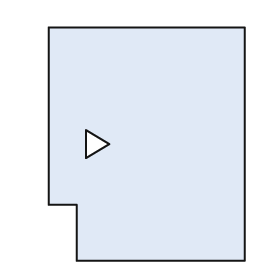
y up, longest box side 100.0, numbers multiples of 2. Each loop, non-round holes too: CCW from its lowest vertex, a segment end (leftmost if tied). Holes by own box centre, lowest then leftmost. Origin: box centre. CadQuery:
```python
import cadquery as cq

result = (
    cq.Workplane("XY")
    .moveTo(-30.0, -50.0)
    .lineTo(42.0, -50.0)
    .lineTo(42.0, 50.0)
    .lineTo(-42.0, 50.0)
    .lineTo(-42.0, -26.0)
    .lineTo(-30.0, -26.0)
    .close()
    .moveTo(-26.0, -6.0)
    .lineTo(-16.0, 0.0)
    .lineTo(-26.0, 6.0)
    .close()
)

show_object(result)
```